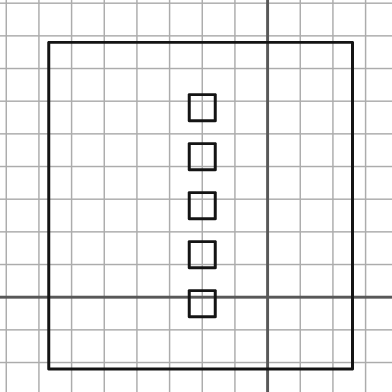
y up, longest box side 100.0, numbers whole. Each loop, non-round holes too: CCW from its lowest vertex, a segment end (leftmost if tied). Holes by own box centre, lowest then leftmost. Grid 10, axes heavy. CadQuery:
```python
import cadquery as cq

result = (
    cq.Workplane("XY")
    .moveTo(-67.0, -22.0)
    .lineTo(26.0, -22.0)
    .lineTo(26.0, 78.0)
    .lineTo(-67.0, 78.0)
    .close()
    .moveTo(-24.0, -6.0)
    .lineTo(-16.0, -6.0)
    .lineTo(-16.0, 2.0)
    .lineTo(-24.0, 2.0)
    .close()
    .moveTo(-24.0, 9.0)
    .lineTo(-16.0, 9.0)
    .lineTo(-16.0, 17.0)
    .lineTo(-24.0, 17.0)
    .close()
    .moveTo(-24.0, 24.0)
    .lineTo(-16.0, 24.0)
    .lineTo(-16.0, 32.0)
    .lineTo(-24.0, 32.0)
    .close()
    .moveTo(-24.0, 39.0)
    .lineTo(-16.0, 39.0)
    .lineTo(-16.0, 47.0)
    .lineTo(-24.0, 47.0)
    .close()
    .moveTo(-24.0, 54.0)
    .lineTo(-16.0, 54.0)
    .lineTo(-16.0, 62.0)
    .lineTo(-24.0, 62.0)
    .close()
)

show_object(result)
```